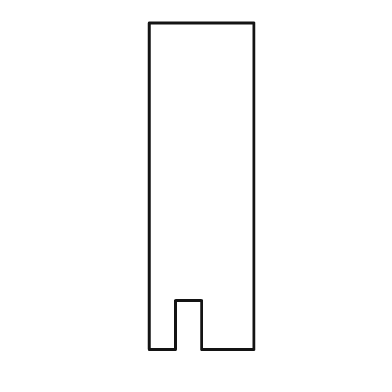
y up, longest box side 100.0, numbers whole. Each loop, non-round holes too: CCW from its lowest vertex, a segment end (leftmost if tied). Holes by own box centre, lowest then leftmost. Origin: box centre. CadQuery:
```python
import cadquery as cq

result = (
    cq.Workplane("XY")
    .moveTo(-16.0, -50.0)
    .lineTo(-8.0, -50.0)
    .lineTo(-8.0, -35.0)
    .lineTo(0.0, -35.0)
    .lineTo(0.0, -50.0)
    .lineTo(16.0, -50.0)
    .lineTo(16.0, 50.0)
    .lineTo(-16.0, 50.0)
    .close()
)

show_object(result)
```